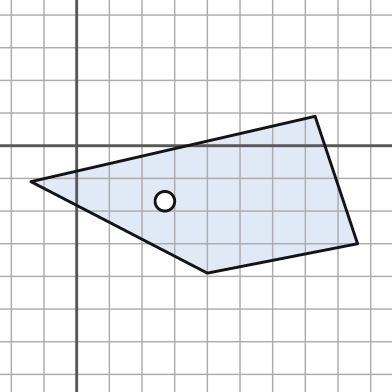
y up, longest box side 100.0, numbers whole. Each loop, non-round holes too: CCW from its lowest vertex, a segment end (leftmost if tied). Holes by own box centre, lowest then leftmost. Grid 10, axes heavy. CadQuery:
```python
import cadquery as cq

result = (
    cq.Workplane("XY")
    .moveTo(40.0, -39.0)
    .lineTo(86.0, -30.0)
    .lineTo(73.0, 9.0)
    .lineTo(-14.0, -11.0)
    .close()
    .moveTo(27.0, -17.0)
    .circle(3.0)
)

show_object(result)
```